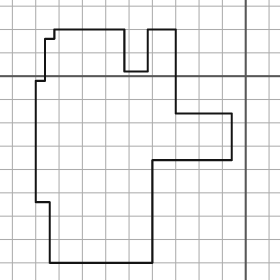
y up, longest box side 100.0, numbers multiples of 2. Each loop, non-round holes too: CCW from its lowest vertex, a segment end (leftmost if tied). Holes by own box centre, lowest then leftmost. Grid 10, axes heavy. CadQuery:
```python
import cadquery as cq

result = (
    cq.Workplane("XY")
    .moveTo(-84.0, -80.0)
    .lineTo(-40.0, -80.0)
    .lineTo(-40.0, -36.0)
    .lineTo(-6.0, -36.0)
    .lineTo(-6.0, -16.0)
    .lineTo(-30.0, -16.0)
    .lineTo(-30.0, 20.0)
    .lineTo(-42.0, 20.0)
    .lineTo(-42.0, 2.0)
    .lineTo(-52.0, 2.0)
    .lineTo(-52.0, 20.0)
    .lineTo(-82.0, 20.0)
    .lineTo(-82.0, 16.0)
    .lineTo(-86.0, 16.0)
    .lineTo(-86.0, -2.0)
    .lineTo(-90.0, -2.0)
    .lineTo(-90.0, -54.0)
    .lineTo(-84.0, -54.0)
    .close()
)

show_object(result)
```